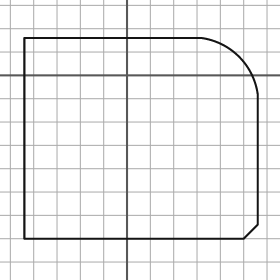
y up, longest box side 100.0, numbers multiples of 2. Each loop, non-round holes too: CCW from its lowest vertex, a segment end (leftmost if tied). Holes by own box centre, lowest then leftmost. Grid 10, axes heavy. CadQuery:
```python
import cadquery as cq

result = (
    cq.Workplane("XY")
    .moveTo(-44.0, -70.0)
    .lineTo(50.0, -70.0)
    .lineTo(56.0, -64.0)
    .lineTo(56.0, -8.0)
    .threePointArc((48.0, 8.0), (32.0, 16.0))
    .lineTo(-44.0, 16.0)
    .close()
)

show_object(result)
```